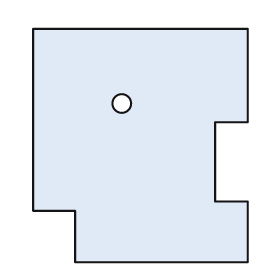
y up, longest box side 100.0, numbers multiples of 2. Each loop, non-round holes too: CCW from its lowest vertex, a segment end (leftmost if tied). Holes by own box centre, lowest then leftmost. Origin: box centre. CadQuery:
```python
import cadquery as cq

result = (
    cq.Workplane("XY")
    .moveTo(-28.0, -50.0)
    .lineTo(46.0, -50.0)
    .lineTo(46.0, -24.0)
    .lineTo(32.0, -24.0)
    .lineTo(32.0, 10.0)
    .lineTo(46.0, 10.0)
    .lineTo(46.0, 50.0)
    .lineTo(-46.0, 50.0)
    .lineTo(-46.0, -28.0)
    .lineTo(-28.0, -28.0)
    .close()
    .moveTo(-8.0, 18.0)
    .circle(4.0)
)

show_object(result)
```